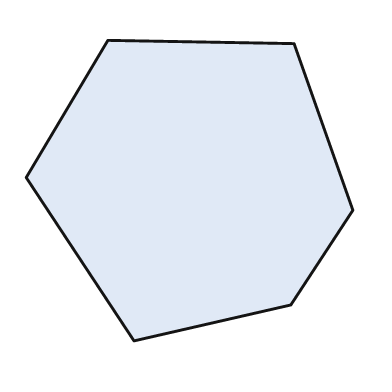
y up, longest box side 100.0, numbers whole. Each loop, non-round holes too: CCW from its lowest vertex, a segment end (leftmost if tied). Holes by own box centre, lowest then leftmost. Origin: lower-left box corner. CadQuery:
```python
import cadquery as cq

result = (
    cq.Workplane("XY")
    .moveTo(33.0, 0.0)
    .lineTo(81.0, 11.0)
    .lineTo(100.0, 40.0)
    .lineTo(82.0, 91.0)
    .lineTo(25.0, 92.0)
    .lineTo(0.0, 50.0)
    .close()
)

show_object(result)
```